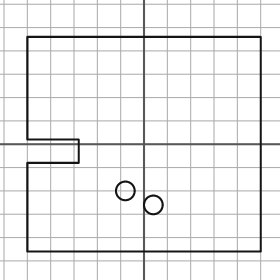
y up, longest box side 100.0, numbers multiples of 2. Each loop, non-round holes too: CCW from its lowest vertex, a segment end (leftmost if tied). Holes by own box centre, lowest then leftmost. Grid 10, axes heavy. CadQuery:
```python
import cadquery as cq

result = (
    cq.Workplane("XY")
    .moveTo(-50.0, -46.0)
    .lineTo(50.0, -46.0)
    .lineTo(50.0, 46.0)
    .lineTo(-50.0, 46.0)
    .lineTo(-50.0, 2.0)
    .lineTo(-28.0, 2.0)
    .lineTo(-28.0, -8.0)
    .lineTo(-50.0, -8.0)
    .close()
    .moveTo(4.0, -26.0)
    .circle(4.0)
    .moveTo(-8.0, -20.0)
    .circle(4.0)
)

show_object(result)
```